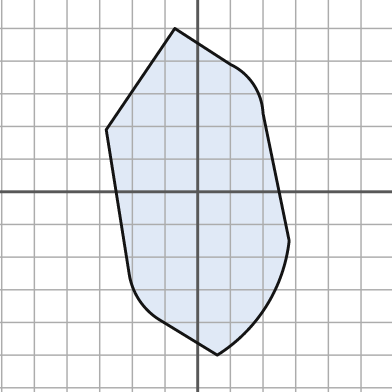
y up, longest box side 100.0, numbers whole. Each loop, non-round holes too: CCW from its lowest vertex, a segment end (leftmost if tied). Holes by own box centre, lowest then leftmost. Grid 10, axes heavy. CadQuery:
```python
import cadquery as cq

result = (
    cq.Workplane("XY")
    .moveTo(6.0, -50.0)
    .threePointArc((21.0, -35.0), (28.0, -15.0))
    .lineTo(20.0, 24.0)
    .threePointArc((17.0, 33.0), (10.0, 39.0))
    .lineTo(-7.0, 50.0)
    .lineTo(-28.0, 19.0)
    .lineTo(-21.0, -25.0)
    .threePointArc((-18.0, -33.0), (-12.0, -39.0))
    .close()
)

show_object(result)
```